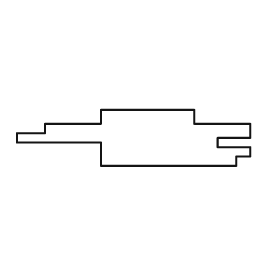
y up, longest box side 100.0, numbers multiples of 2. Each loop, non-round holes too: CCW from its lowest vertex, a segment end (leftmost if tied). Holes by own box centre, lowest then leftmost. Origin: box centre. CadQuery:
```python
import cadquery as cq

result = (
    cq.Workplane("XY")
    .moveTo(-14.0, -12.0)
    .lineTo(44.0, -12.0)
    .lineTo(44.0, -8.0)
    .lineTo(50.0, -8.0)
    .lineTo(50.0, -4.0)
    .lineTo(36.0, -4.0)
    .lineTo(36.0, 0.0)
    .lineTo(50.0, 0.0)
    .lineTo(50.0, 6.0)
    .lineTo(26.0, 6.0)
    .lineTo(26.0, 12.0)
    .lineTo(-14.0, 12.0)
    .lineTo(-14.0, 6.0)
    .lineTo(-38.0, 6.0)
    .lineTo(-38.0, 2.0)
    .lineTo(-50.0, 2.0)
    .lineTo(-50.0, -2.0)
    .lineTo(-14.0, -2.0)
    .close()
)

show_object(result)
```